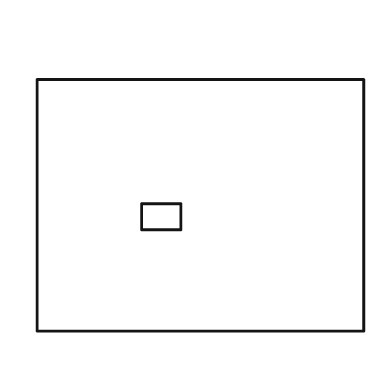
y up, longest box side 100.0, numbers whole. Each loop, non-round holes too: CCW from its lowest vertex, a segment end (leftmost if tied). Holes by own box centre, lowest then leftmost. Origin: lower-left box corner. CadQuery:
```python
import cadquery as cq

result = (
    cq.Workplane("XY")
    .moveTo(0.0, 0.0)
    .lineTo(100.0, 0.0)
    .lineTo(100.0, 77.0)
    .lineTo(0.0, 77.0)
    .close()
    .moveTo(32.0, 31.0)
    .lineTo(44.0, 31.0)
    .lineTo(44.0, 39.0)
    .lineTo(32.0, 39.0)
    .close()
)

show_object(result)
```